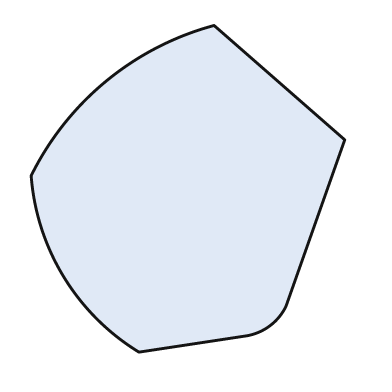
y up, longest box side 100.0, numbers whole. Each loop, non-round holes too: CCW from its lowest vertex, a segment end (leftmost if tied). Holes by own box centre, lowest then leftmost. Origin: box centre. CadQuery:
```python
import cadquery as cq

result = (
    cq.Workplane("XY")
    .moveTo(-15.0, -50.0)
    .lineTo(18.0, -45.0)
    .threePointArc((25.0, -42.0), (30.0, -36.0))
    .lineTo(48.0, 15.0)
    .lineTo(8.0, 50.0)
    .threePointArc((-25.0, 33.0), (-48.0, 4.0))
    .threePointArc((-38.0, -27.0), (-15.0, -50.0))
    .close()
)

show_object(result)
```